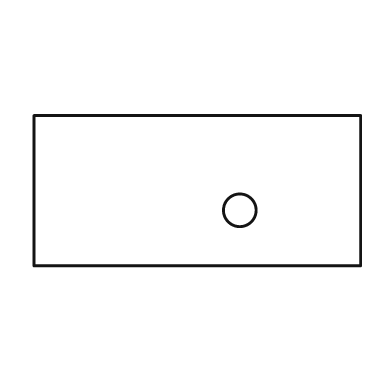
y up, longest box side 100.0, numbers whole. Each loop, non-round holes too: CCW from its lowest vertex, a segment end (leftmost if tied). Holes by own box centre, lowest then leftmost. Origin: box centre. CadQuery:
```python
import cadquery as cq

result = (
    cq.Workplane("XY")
    .moveTo(-50.0, -23.0)
    .lineTo(50.0, -23.0)
    .lineTo(50.0, 23.0)
    .lineTo(-50.0, 23.0)
    .close()
    .moveTo(13.0, -6.0)
    .circle(5.0)
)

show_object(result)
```